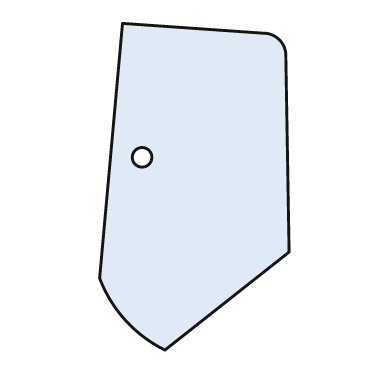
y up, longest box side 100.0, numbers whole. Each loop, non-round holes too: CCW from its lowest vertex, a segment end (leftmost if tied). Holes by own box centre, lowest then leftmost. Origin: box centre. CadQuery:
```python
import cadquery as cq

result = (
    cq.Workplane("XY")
    .moveTo(-9.0, -50.0)
    .lineTo(29.0, -20.0)
    .lineTo(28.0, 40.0)
    .threePointArc((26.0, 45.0), (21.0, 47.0))
    .lineTo(-22.0, 50.0)
    .lineTo(-29.0, -28.0)
    .threePointArc((-21.0, -41.0), (-9.0, -50.0))
    .close()
    .moveTo(-16.0, 9.0)
    .circle(3.0)
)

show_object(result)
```